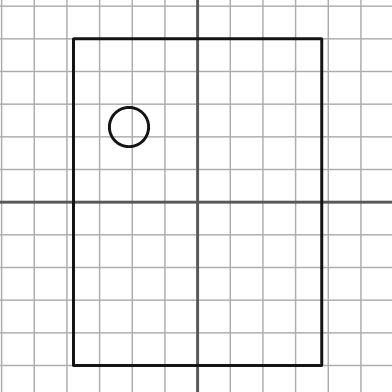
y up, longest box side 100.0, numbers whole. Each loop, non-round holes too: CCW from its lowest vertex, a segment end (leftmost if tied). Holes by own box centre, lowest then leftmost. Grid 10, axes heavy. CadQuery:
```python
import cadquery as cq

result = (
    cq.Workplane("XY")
    .moveTo(-38.0, -50.0)
    .lineTo(38.0, -50.0)
    .lineTo(38.0, 50.0)
    .lineTo(-38.0, 50.0)
    .close()
    .moveTo(-21.0, 23.0)
    .circle(6.0)
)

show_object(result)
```